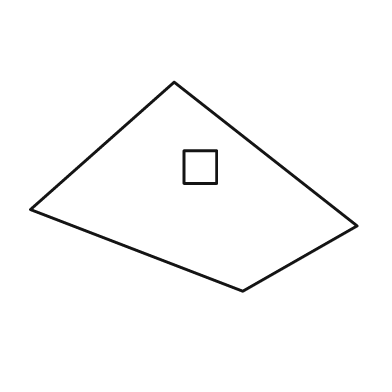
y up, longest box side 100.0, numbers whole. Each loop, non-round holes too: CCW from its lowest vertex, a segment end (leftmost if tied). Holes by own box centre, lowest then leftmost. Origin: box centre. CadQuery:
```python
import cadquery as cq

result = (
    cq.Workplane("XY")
    .moveTo(15.0, -32.0)
    .lineTo(50.0, -12.0)
    .lineTo(-6.0, 32.0)
    .lineTo(-50.0, -7.0)
    .close()
    .moveTo(-3.0, 1.0)
    .lineTo(7.0, 1.0)
    .lineTo(7.0, 11.0)
    .lineTo(-3.0, 11.0)
    .close()
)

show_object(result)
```